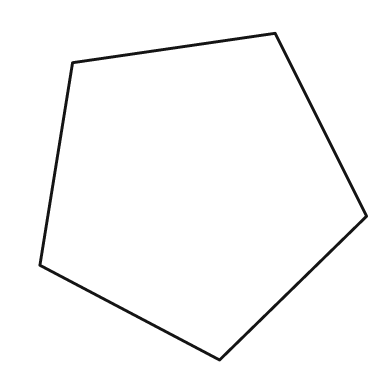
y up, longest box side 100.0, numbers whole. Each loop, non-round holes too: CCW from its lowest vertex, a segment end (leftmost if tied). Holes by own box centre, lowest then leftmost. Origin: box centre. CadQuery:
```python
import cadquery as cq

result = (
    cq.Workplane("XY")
    .moveTo(5.0, -50.0)
    .lineTo(50.0, -6.0)
    .lineTo(22.0, 50.0)
    .lineTo(-40.0, 41.0)
    .lineTo(-50.0, -21.0)
    .close()
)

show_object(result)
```